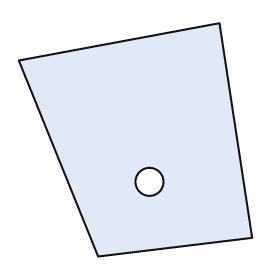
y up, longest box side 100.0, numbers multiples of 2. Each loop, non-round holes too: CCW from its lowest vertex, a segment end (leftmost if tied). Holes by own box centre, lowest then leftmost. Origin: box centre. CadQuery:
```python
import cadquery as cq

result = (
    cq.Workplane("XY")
    .moveTo(-16.0, -50.0)
    .lineTo(50.0, -42.0)
    .lineTo(36.0, 50.0)
    .lineTo(-50.0, 34.0)
    .close()
    .moveTo(6.0, -18.0)
    .circle(6.0)
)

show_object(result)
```